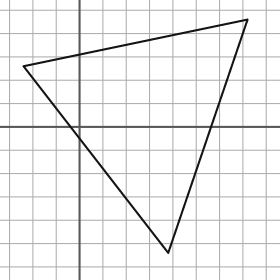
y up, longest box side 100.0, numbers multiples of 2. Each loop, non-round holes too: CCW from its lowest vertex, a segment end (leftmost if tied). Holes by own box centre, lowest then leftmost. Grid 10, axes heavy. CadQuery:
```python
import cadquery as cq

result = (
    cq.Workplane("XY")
    .moveTo(38.0, -54.0)
    .lineTo(72.0, 46.0)
    .lineTo(-24.0, 26.0)
    .close()
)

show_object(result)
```